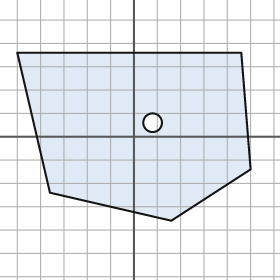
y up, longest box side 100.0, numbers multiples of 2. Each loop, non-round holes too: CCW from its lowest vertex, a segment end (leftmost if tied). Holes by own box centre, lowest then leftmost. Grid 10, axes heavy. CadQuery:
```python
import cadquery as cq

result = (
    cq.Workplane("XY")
    .moveTo(16.0, -36.0)
    .lineTo(50.0, -14.0)
    .lineTo(46.0, 36.0)
    .lineTo(-50.0, 36.0)
    .lineTo(-36.0, -24.0)
    .close()
    .moveTo(8.0, 6.0)
    .circle(4.0)
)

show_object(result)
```